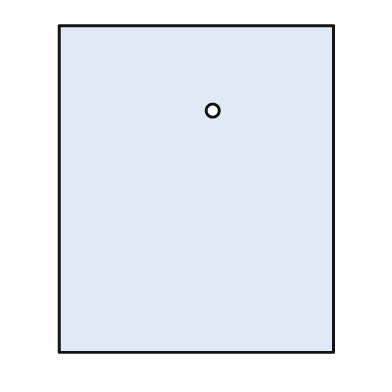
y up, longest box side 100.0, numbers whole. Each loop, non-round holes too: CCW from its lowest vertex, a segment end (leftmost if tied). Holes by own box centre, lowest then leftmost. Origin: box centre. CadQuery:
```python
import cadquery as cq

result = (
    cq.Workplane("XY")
    .moveTo(-42.0, -50.0)
    .lineTo(42.0, -50.0)
    .lineTo(42.0, 50.0)
    .lineTo(-42.0, 50.0)
    .close()
    .moveTo(5.0, 24.0)
    .circle(2.0)
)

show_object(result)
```